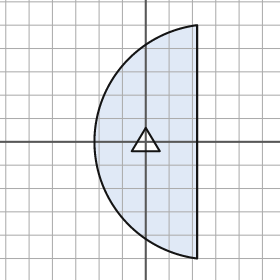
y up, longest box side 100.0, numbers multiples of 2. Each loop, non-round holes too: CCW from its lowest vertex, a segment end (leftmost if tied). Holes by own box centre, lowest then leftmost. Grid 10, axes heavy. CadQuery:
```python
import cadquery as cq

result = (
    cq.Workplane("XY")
    .moveTo(22.0, -50.0)
    .lineTo(22.0, 50.0)
    .threePointArc((-22.0, 0.0), (22.0, -50.0))
    .close()
    .moveTo(-6.0, -4.0)
    .lineTo(6.0, -4.0)
    .lineTo(0.0, 6.0)
    .close()
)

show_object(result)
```